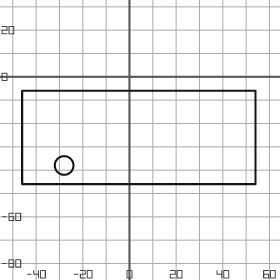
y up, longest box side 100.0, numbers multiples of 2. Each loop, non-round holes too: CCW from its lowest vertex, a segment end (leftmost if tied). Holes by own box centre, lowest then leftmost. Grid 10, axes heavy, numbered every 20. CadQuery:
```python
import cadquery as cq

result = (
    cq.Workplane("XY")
    .moveTo(-46.0, -46.0)
    .lineTo(54.0, -46.0)
    .lineTo(54.0, -6.0)
    .lineTo(-46.0, -6.0)
    .close()
    .moveTo(-28.0, -38.0)
    .circle(4.0)
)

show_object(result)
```